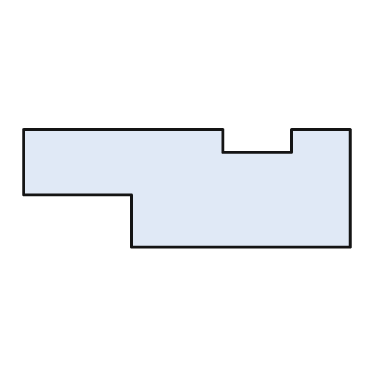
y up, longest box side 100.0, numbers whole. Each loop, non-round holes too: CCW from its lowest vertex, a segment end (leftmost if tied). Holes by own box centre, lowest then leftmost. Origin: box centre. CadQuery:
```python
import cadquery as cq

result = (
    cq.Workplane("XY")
    .moveTo(-17.0, -18.0)
    .lineTo(50.0, -18.0)
    .lineTo(50.0, 18.0)
    .lineTo(32.0, 18.0)
    .lineTo(32.0, 11.0)
    .lineTo(11.0, 11.0)
    .lineTo(11.0, 18.0)
    .lineTo(-50.0, 18.0)
    .lineTo(-50.0, -2.0)
    .lineTo(-17.0, -2.0)
    .close()
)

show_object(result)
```